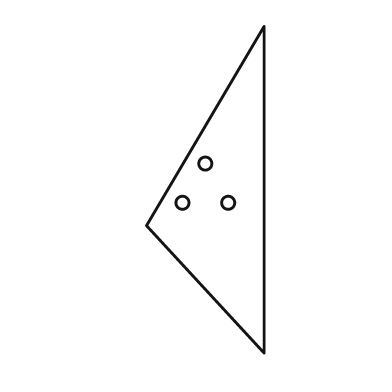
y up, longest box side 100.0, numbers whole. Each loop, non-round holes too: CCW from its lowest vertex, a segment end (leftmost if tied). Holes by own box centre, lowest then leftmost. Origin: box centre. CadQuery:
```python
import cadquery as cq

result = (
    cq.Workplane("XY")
    .moveTo(18.0, -50.0)
    .lineTo(18.0, 50.0)
    .lineTo(-18.0, -11.0)
    .close()
    .moveTo(-7.0, -4.0)
    .circle(2.0)
    .moveTo(7.0, -4.0)
    .circle(2.0)
    .moveTo(0.0, 8.0)
    .circle(2.0)
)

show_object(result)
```